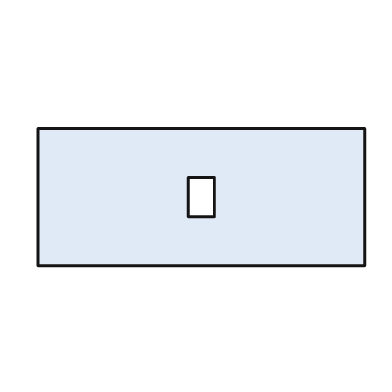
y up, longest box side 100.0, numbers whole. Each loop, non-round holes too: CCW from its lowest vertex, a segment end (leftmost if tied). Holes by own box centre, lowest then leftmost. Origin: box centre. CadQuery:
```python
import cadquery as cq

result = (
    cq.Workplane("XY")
    .moveTo(-50.0, -21.0)
    .lineTo(50.0, -21.0)
    .lineTo(50.0, 21.0)
    .lineTo(-50.0, 21.0)
    .close()
    .moveTo(-4.0, -6.0)
    .lineTo(4.0, -6.0)
    .lineTo(4.0, 6.0)
    .lineTo(-4.0, 6.0)
    .close()
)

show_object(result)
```